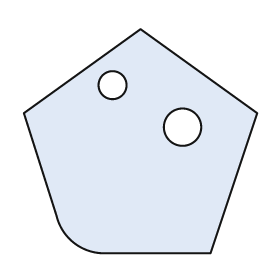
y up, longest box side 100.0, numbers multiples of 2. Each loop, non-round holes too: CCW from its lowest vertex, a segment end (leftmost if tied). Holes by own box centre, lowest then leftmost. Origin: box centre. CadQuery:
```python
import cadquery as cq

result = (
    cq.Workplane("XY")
    .moveTo(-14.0, -48.0)
    .lineTo(30.0, -48.0)
    .lineTo(50.0, 12.0)
    .lineTo(0.0, 48.0)
    .lineTo(-50.0, 12.0)
    .lineTo(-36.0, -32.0)
    .threePointArc((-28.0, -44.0), (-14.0, -48.0))
    .close()
    .moveTo(18.0, 6.0)
    .circle(8.0)
    .moveTo(-12.0, 24.0)
    .circle(6.0)
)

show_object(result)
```